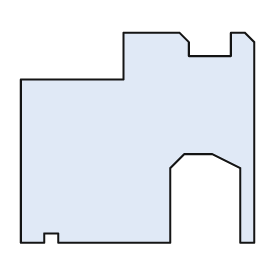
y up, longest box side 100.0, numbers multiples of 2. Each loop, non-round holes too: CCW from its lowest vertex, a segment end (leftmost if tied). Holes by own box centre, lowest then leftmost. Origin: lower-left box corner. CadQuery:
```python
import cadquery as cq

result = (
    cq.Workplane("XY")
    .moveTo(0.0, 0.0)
    .lineTo(10.0, 0.0)
    .lineTo(10.0, 4.0)
    .lineTo(16.0, 4.0)
    .lineTo(16.0, 0.0)
    .lineTo(64.0, 0.0)
    .lineTo(64.0, 32.0)
    .lineTo(70.0, 38.0)
    .lineTo(82.0, 38.0)
    .lineTo(94.0, 32.0)
    .lineTo(94.0, 0.0)
    .lineTo(100.0, 0.0)
    .lineTo(100.0, 86.0)
    .lineTo(96.0, 90.0)
    .lineTo(90.0, 90.0)
    .lineTo(90.0, 80.0)
    .lineTo(72.0, 80.0)
    .lineTo(72.0, 86.0)
    .lineTo(68.0, 90.0)
    .lineTo(44.0, 90.0)
    .lineTo(44.0, 70.0)
    .lineTo(0.0, 70.0)
    .close()
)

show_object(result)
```